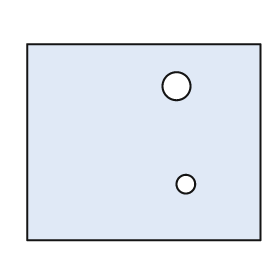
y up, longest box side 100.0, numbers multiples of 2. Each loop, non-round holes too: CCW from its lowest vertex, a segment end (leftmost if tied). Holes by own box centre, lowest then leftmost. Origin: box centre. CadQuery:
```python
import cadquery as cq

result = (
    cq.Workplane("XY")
    .moveTo(-50.0, -42.0)
    .lineTo(50.0, -42.0)
    .lineTo(50.0, 42.0)
    .lineTo(-50.0, 42.0)
    .close()
    .moveTo(18.0, -18.0)
    .circle(4.0)
    .moveTo(14.0, 24.0)
    .circle(6.0)
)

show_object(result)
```